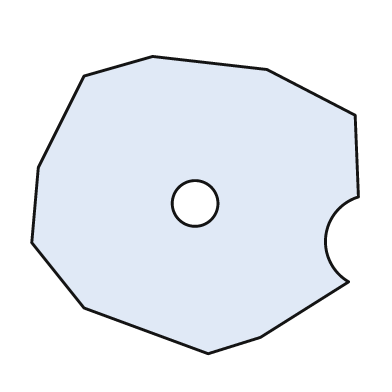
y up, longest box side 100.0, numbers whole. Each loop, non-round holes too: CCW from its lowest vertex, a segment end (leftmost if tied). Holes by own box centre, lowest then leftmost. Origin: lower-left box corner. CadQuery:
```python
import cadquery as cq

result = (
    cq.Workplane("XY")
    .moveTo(54.0, 0.0)
    .lineTo(70.0, 5.0)
    .lineTo(97.0, 22.0)
    .threePointArc((90.0, 36.0), (100.0, 48.0))
    .lineTo(99.0, 73.0)
    .lineTo(72.0, 87.0)
    .lineTo(37.0, 91.0)
    .lineTo(16.0, 85.0)
    .lineTo(2.0, 57.0)
    .lineTo(0.0, 34.0)
    .lineTo(16.0, 14.0)
    .close()
    .moveTo(50.0, 46.0)
    .circle(7.0)
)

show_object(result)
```